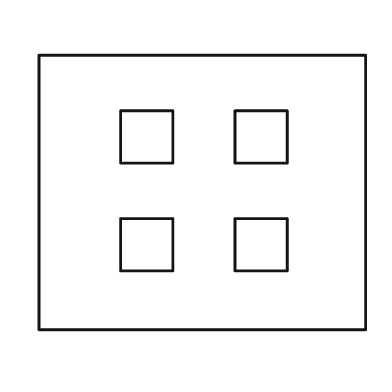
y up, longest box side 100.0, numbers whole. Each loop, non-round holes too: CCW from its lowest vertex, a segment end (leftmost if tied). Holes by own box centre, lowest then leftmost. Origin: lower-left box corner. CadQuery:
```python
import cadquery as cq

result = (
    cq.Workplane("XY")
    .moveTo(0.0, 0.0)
    .lineTo(100.0, 0.0)
    .lineTo(100.0, 84.0)
    .lineTo(0.0, 84.0)
    .close()
    .moveTo(25.0, 18.0)
    .lineTo(41.0, 18.0)
    .lineTo(41.0, 34.0)
    .lineTo(25.0, 34.0)
    .close()
    .moveTo(60.0, 18.0)
    .lineTo(76.0, 18.0)
    .lineTo(76.0, 34.0)
    .lineTo(60.0, 34.0)
    .close()
    .moveTo(25.0, 51.0)
    .lineTo(41.0, 51.0)
    .lineTo(41.0, 67.0)
    .lineTo(25.0, 67.0)
    .close()
    .moveTo(60.0, 51.0)
    .lineTo(76.0, 51.0)
    .lineTo(76.0, 67.0)
    .lineTo(60.0, 67.0)
    .close()
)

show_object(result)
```